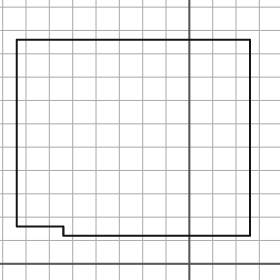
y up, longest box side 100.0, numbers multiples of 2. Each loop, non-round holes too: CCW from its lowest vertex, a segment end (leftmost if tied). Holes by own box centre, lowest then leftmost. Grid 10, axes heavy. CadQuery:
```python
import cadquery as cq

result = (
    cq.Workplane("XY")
    .moveTo(-54.0, 12.0)
    .lineTo(26.0, 12.0)
    .lineTo(26.0, 96.0)
    .lineTo(-74.0, 96.0)
    .lineTo(-74.0, 16.0)
    .lineTo(-54.0, 16.0)
    .close()
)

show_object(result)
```